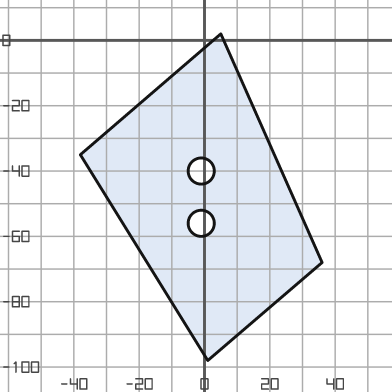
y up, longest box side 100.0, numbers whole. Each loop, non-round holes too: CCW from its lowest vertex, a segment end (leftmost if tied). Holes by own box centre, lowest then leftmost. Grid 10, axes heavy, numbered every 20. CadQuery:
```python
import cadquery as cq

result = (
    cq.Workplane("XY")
    .moveTo(1.0, -98.0)
    .lineTo(36.0, -68.0)
    .lineTo(5.0, 2.0)
    .lineTo(-38.0, -35.0)
    .close()
    .moveTo(-1.0, -56.0)
    .circle(4.0)
    .moveTo(-1.0, -40.0)
    .circle(4.0)
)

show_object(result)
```